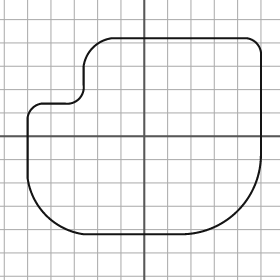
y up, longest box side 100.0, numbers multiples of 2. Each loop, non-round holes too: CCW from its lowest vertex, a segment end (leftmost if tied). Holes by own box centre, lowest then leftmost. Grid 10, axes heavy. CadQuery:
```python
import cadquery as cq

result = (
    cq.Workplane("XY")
    .moveTo(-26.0, -42.0)
    .lineTo(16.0, -42.0)
    .threePointArc((40.0, -32.0), (50.0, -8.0))
    .lineTo(50.0, 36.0)
    .threePointArc((48.0, 40.0), (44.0, 42.0))
    .lineTo(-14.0, 42.0)
    .threePointArc((-22.0, 38.0), (-26.0, 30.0))
    .lineTo(-26.0, 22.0)
    .threePointArc((-28.0, 16.0), (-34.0, 14.0))
    .lineTo(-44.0, 14.0)
    .threePointArc((-48.0, 12.0), (-50.0, 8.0))
    .lineTo(-50.0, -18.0)
    .threePointArc((-42.0, -34.0), (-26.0, -42.0))
    .close()
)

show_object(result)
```